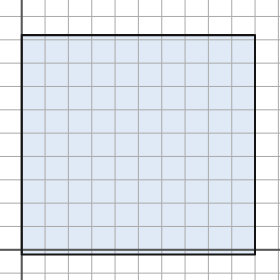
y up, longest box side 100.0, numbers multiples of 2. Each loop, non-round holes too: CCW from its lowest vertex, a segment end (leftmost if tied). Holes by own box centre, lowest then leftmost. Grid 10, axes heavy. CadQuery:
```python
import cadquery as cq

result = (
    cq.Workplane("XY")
    .moveTo(0.0, -2.0)
    .lineTo(100.0, -2.0)
    .lineTo(100.0, 92.0)
    .lineTo(0.0, 92.0)
    .close()
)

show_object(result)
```